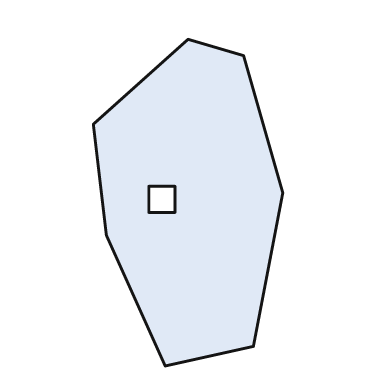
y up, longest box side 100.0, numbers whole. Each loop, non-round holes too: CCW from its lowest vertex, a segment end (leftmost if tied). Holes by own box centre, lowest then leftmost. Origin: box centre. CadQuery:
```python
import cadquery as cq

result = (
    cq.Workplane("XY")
    .moveTo(-7.0, -50.0)
    .lineTo(20.0, -44.0)
    .lineTo(29.0, 3.0)
    .lineTo(17.0, 45.0)
    .lineTo(0.0, 50.0)
    .lineTo(-29.0, 24.0)
    .lineTo(-25.0, -10.0)
    .close()
    .moveTo(-12.0, -3.0)
    .lineTo(-4.0, -3.0)
    .lineTo(-4.0, 5.0)
    .lineTo(-12.0, 5.0)
    .close()
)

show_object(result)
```